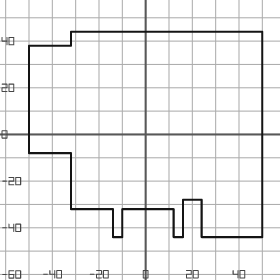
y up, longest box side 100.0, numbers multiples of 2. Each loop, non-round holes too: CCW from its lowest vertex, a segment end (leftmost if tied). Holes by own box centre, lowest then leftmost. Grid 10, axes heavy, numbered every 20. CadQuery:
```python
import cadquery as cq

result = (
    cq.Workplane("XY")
    .moveTo(-14.0, -44.0)
    .lineTo(-10.0, -44.0)
    .lineTo(-10.0, -32.0)
    .lineTo(12.0, -32.0)
    .lineTo(12.0, -44.0)
    .lineTo(16.0, -44.0)
    .lineTo(16.0, -28.0)
    .lineTo(24.0, -28.0)
    .lineTo(24.0, -44.0)
    .lineTo(50.0, -44.0)
    .lineTo(50.0, 44.0)
    .lineTo(-32.0, 44.0)
    .lineTo(-32.0, 38.0)
    .lineTo(-50.0, 38.0)
    .lineTo(-50.0, -8.0)
    .lineTo(-32.0, -8.0)
    .lineTo(-32.0, -32.0)
    .lineTo(-14.0, -32.0)
    .close()
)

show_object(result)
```